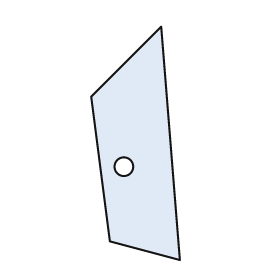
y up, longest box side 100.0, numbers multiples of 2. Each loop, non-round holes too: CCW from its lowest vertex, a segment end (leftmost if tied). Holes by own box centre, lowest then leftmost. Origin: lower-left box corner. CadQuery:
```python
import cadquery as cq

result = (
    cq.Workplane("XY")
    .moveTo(38.0, 0.0)
    .lineTo(30.0, 100.0)
    .lineTo(0.0, 70.0)
    .lineTo(8.0, 8.0)
    .close()
    .moveTo(14.0, 40.0)
    .circle(4.0)
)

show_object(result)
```